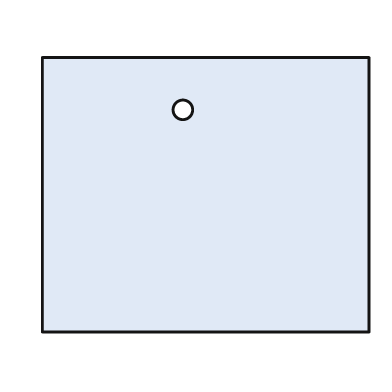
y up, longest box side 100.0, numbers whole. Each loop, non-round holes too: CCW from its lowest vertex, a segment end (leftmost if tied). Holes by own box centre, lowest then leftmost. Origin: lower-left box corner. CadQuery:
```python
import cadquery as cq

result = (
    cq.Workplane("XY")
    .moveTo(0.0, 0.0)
    .lineTo(100.0, 0.0)
    .lineTo(100.0, 84.0)
    .lineTo(0.0, 84.0)
    .close()
    .moveTo(43.0, 68.0)
    .circle(3.0)
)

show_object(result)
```